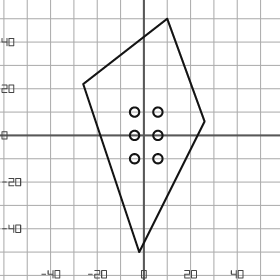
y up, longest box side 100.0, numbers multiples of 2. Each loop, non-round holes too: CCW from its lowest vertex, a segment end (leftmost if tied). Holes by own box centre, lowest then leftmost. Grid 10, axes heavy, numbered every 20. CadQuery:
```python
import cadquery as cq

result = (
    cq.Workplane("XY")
    .moveTo(-2.0, -50.0)
    .lineTo(26.0, 6.0)
    .lineTo(10.0, 50.0)
    .lineTo(-26.0, 22.0)
    .close()
    .moveTo(-4.0, -10.0)
    .circle(2.0)
    .moveTo(6.0, -10.0)
    .circle(2.0)
    .moveTo(-4.0, 0.0)
    .circle(2.0)
    .moveTo(6.0, 0.0)
    .circle(2.0)
    .moveTo(-4.0, 10.0)
    .circle(2.0)
    .moveTo(6.0, 10.0)
    .circle(2.0)
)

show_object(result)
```